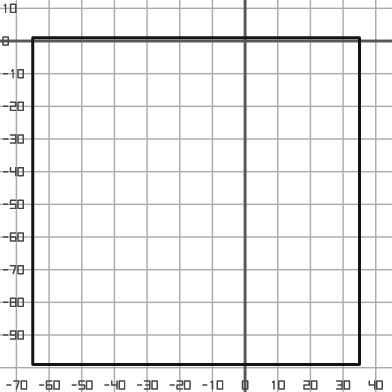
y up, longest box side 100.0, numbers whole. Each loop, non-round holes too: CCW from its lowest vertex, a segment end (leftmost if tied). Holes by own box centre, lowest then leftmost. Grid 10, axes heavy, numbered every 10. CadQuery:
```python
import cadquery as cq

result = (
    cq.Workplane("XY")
    .moveTo(-65.0, -99.0)
    .lineTo(35.0, -99.0)
    .lineTo(35.0, 1.0)
    .lineTo(-65.0, 1.0)
    .close()
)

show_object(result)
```